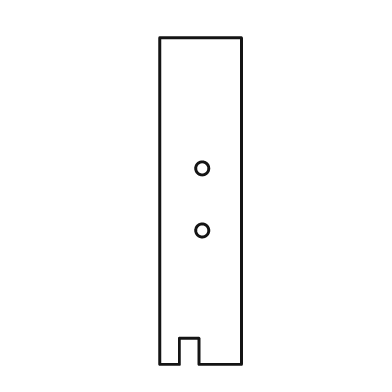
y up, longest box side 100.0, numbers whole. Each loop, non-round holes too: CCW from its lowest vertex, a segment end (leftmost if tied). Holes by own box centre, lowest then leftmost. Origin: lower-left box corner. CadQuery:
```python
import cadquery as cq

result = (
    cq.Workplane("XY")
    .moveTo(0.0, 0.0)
    .lineTo(6.0, 0.0)
    .lineTo(6.0, 8.0)
    .lineTo(12.0, 8.0)
    .lineTo(12.0, 0.0)
    .lineTo(25.0, 0.0)
    .lineTo(25.0, 100.0)
    .lineTo(0.0, 100.0)
    .close()
    .moveTo(13.0, 41.0)
    .circle(2.0)
    .moveTo(13.0, 60.0)
    .circle(2.0)
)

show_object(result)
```